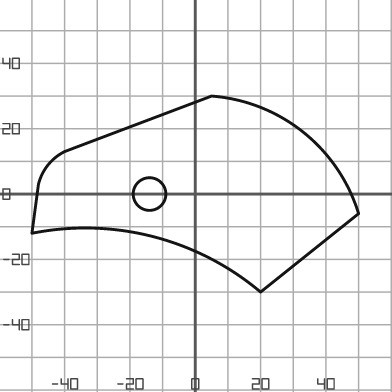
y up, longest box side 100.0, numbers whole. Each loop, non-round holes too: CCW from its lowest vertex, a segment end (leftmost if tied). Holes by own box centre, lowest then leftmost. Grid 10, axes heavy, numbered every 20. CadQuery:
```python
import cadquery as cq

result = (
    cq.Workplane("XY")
    .moveTo(20.0, -30.0)
    .lineTo(50.0, -6.0)
    .threePointArc((33.0, 19.0), (5.0, 30.0))
    .lineTo(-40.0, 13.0)
    .threePointArc((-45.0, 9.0), (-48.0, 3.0))
    .lineTo(-50.0, -12.0)
    .threePointArc((-13.0, -13.0), (20.0, -30.0))
    .close()
    .moveTo(-14.0, 0.0)
    .circle(5.0)
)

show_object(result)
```